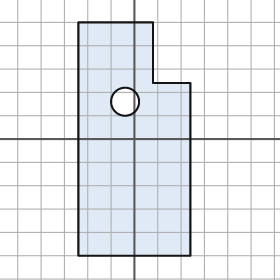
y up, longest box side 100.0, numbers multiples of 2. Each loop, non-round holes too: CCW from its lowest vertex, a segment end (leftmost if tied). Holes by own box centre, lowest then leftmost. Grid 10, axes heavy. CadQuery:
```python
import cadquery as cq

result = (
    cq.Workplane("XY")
    .moveTo(-24.0, -50.0)
    .lineTo(24.0, -50.0)
    .lineTo(24.0, 24.0)
    .lineTo(8.0, 24.0)
    .lineTo(8.0, 50.0)
    .lineTo(-24.0, 50.0)
    .close()
    .moveTo(-4.0, 16.0)
    .circle(6.0)
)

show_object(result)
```